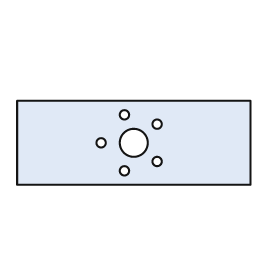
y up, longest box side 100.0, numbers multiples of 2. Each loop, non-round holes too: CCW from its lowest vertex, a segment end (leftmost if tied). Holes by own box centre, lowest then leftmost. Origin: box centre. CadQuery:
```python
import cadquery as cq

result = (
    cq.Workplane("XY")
    .moveTo(-50.0, -18.0)
    .lineTo(50.0, -18.0)
    .lineTo(50.0, 18.0)
    .lineTo(-50.0, 18.0)
    .close()
    .moveTo(-4.0, -12.0)
    .circle(2.0)
    .moveTo(10.0, -8.0)
    .circle(2.0)
    .moveTo(-14.0, 0.0)
    .circle(2.0)
    .moveTo(0.0, 0.0)
    .circle(6.0)
    .moveTo(10.0, 8.0)
    .circle(2.0)
    .moveTo(-4.0, 12.0)
    .circle(2.0)
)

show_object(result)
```